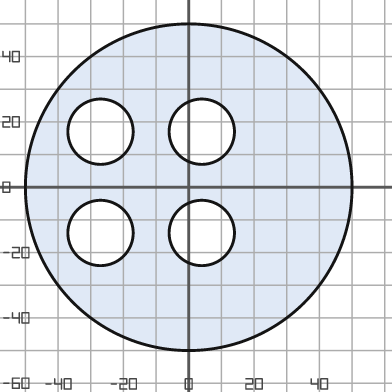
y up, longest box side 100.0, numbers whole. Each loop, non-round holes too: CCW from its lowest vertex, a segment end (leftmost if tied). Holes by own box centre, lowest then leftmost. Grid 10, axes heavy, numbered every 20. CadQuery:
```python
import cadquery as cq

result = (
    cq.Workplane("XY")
    .moveTo(0.0, 0.0)
    .circle(50.0)
    .moveTo(-27.0, -14.0)
    .circle(10.0)
    .moveTo(4.0, -14.0)
    .circle(10.0)
    .moveTo(-27.0, 17.0)
    .circle(10.0)
    .moveTo(4.0, 17.0)
    .circle(10.0)
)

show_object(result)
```